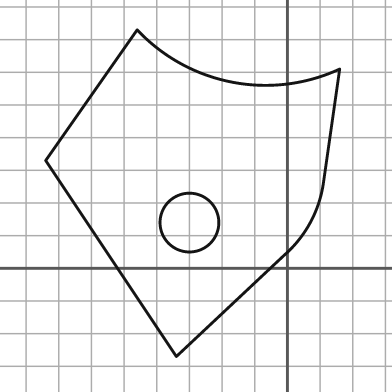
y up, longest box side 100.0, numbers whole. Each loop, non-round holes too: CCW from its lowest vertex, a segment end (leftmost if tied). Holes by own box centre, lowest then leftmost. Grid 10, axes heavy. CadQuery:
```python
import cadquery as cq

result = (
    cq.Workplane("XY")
    .moveTo(-34.0, -27.0)
    .lineTo(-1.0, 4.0)
    .threePointArc((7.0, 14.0), (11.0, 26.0))
    .lineTo(16.0, 61.0)
    .threePointArc((-17.0, 57.0), (-46.0, 73.0))
    .lineTo(-74.0, 33.0)
    .close()
    .moveTo(-30.0, 14.0)
    .circle(9.0)
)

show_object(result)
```